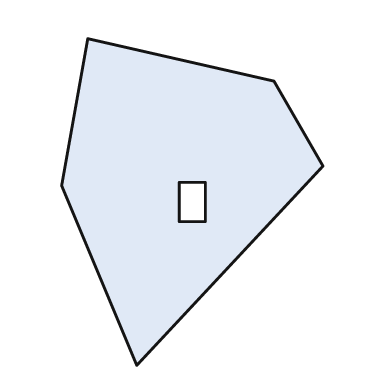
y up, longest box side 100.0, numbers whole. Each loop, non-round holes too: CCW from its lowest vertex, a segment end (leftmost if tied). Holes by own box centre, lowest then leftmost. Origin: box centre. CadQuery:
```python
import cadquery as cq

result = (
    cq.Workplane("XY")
    .moveTo(-17.0, -50.0)
    .lineTo(40.0, 11.0)
    .lineTo(25.0, 37.0)
    .lineTo(-32.0, 50.0)
    .lineTo(-40.0, 5.0)
    .close()
    .moveTo(-4.0, -6.0)
    .lineTo(4.0, -6.0)
    .lineTo(4.0, 6.0)
    .lineTo(-4.0, 6.0)
    .close()
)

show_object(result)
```